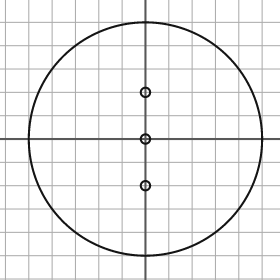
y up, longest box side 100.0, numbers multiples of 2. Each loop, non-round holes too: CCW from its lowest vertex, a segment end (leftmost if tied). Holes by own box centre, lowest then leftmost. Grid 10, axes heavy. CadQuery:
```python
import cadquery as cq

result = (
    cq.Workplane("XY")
    .moveTo(0.0, 0.0)
    .circle(50.0)
    .moveTo(0.0, -20.0)
    .circle(2.0)
    .moveTo(0.0, 0.0)
    .circle(2.0)
    .moveTo(0.0, 20.0)
    .circle(2.0)
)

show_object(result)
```